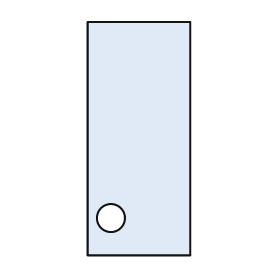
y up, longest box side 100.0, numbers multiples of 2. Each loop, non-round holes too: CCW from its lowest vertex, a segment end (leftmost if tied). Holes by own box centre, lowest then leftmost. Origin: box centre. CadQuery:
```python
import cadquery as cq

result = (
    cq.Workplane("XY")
    .moveTo(-22.0, -50.0)
    .lineTo(22.0, -50.0)
    .lineTo(22.0, 50.0)
    .lineTo(-22.0, 50.0)
    .close()
    .moveTo(-12.0, -34.0)
    .circle(6.0)
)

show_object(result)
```